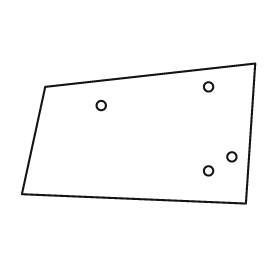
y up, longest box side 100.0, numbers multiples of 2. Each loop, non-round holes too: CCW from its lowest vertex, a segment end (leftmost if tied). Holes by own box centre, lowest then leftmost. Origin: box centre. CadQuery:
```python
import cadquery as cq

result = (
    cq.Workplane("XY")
    .moveTo(46.0, -30.0)
    .lineTo(50.0, 30.0)
    .lineTo(-40.0, 20.0)
    .lineTo(-50.0, -26.0)
    .close()
    .moveTo(30.0, -16.0)
    .circle(2.0)
    .moveTo(40.0, -10.0)
    .circle(2.0)
    .moveTo(-16.0, 12.0)
    .circle(2.0)
    .moveTo(30.0, 20.0)
    .circle(2.0)
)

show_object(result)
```